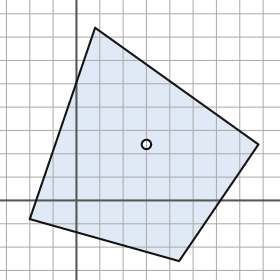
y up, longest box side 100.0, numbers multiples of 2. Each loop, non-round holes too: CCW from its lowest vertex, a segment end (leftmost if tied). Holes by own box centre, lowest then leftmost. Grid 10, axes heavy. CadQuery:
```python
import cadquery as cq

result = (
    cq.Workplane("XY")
    .moveTo(44.0, -26.0)
    .lineTo(78.0, 24.0)
    .lineTo(8.0, 74.0)
    .lineTo(-20.0, -8.0)
    .close()
    .moveTo(30.0, 24.0)
    .circle(2.0)
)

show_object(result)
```